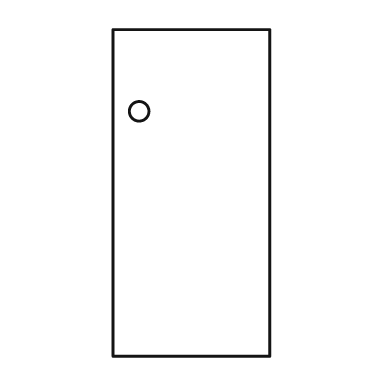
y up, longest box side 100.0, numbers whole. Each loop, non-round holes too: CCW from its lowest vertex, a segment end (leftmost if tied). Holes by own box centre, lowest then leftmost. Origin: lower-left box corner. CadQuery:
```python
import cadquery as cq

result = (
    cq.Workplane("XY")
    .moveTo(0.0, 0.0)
    .lineTo(48.0, 0.0)
    .lineTo(48.0, 100.0)
    .lineTo(0.0, 100.0)
    .close()
    .moveTo(8.0, 75.0)
    .circle(3.0)
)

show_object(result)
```